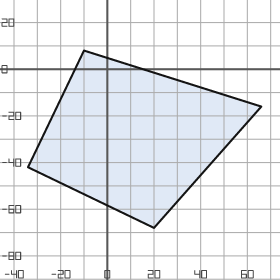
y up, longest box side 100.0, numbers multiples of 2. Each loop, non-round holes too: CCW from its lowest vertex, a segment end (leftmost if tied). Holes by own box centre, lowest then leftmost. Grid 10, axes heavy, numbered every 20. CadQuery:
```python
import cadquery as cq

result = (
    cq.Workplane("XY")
    .moveTo(20.0, -68.0)
    .lineTo(66.0, -16.0)
    .lineTo(-10.0, 8.0)
    .lineTo(-34.0, -42.0)
    .close()
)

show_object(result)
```